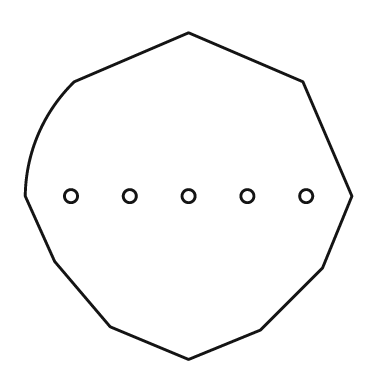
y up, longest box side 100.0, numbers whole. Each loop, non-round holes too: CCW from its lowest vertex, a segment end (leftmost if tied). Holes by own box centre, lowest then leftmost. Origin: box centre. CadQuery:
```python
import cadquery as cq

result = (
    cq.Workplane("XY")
    .moveTo(0.0, -50.0)
    .lineTo(22.0, -41.0)
    .lineTo(41.0, -22.0)
    .lineTo(50.0, 0.0)
    .lineTo(35.0, 35.0)
    .lineTo(0.0, 50.0)
    .lineTo(-35.0, 35.0)
    .threePointArc((-46.0, 19.0), (-50.0, 0.0))
    .lineTo(-41.0, -20.0)
    .lineTo(-24.0, -40.0)
    .close()
    .moveTo(-36.0, 0.0)
    .circle(2.0)
    .moveTo(-18.0, 0.0)
    .circle(2.0)
    .moveTo(0.0, 0.0)
    .circle(2.0)
    .moveTo(18.0, 0.0)
    .circle(2.0)
    .moveTo(36.0, 0.0)
    .circle(2.0)
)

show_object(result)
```